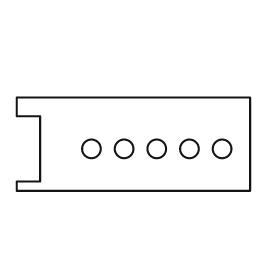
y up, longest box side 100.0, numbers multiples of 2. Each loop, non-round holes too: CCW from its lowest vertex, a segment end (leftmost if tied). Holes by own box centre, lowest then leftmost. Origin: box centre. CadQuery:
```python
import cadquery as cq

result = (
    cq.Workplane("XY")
    .moveTo(-50.0, -20.0)
    .lineTo(50.0, -20.0)
    .lineTo(50.0, 20.0)
    .lineTo(-50.0, 20.0)
    .lineTo(-50.0, 12.0)
    .lineTo(-40.0, 12.0)
    .lineTo(-40.0, -16.0)
    .lineTo(-50.0, -16.0)
    .close()
    .moveTo(-18.0, -2.0)
    .circle(4.0)
    .moveTo(-4.0, -2.0)
    .circle(4.0)
    .moveTo(10.0, -2.0)
    .circle(4.0)
    .moveTo(24.0, -2.0)
    .circle(4.0)
    .moveTo(38.0, -2.0)
    .circle(4.0)
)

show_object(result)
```